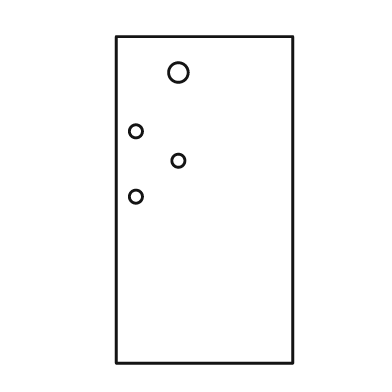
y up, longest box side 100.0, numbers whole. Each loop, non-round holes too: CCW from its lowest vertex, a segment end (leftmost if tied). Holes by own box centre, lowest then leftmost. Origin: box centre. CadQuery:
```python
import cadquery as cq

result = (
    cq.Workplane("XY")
    .moveTo(-27.0, -50.0)
    .lineTo(27.0, -50.0)
    .lineTo(27.0, 50.0)
    .lineTo(-27.0, 50.0)
    .close()
    .moveTo(-21.0, 1.0)
    .circle(2.0)
    .moveTo(-8.0, 12.0)
    .circle(2.0)
    .moveTo(-21.0, 21.0)
    .circle(2.0)
    .moveTo(-8.0, 39.0)
    .circle(3.0)
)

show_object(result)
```